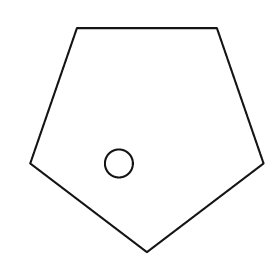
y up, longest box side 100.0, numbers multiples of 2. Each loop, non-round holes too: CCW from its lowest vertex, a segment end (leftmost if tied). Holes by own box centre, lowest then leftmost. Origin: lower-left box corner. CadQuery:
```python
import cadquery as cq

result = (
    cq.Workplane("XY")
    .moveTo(50.0, 0.0)
    .lineTo(100.0, 38.0)
    .lineTo(80.0, 96.0)
    .lineTo(20.0, 96.0)
    .lineTo(0.0, 38.0)
    .close()
    .moveTo(38.0, 38.0)
    .circle(6.0)
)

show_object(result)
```